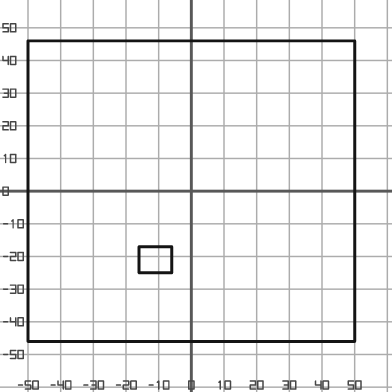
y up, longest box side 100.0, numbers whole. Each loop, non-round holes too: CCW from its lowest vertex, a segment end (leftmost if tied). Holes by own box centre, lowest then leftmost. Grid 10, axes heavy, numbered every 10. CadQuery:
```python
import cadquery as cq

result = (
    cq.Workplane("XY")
    .moveTo(-50.0, -46.0)
    .lineTo(50.0, -46.0)
    .lineTo(50.0, 46.0)
    .lineTo(-50.0, 46.0)
    .close()
    .moveTo(-16.0, -25.0)
    .lineTo(-6.0, -25.0)
    .lineTo(-6.0, -17.0)
    .lineTo(-16.0, -17.0)
    .close()
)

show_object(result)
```